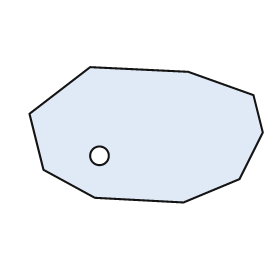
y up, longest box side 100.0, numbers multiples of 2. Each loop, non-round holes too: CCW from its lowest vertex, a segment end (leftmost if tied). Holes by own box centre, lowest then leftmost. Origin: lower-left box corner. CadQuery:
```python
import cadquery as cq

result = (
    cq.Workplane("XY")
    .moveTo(66.0, 0.0)
    .lineTo(90.0, 10.0)
    .lineTo(100.0, 30.0)
    .lineTo(96.0, 46.0)
    .lineTo(68.0, 56.0)
    .lineTo(26.0, 58.0)
    .lineTo(0.0, 38.0)
    .lineTo(6.0, 14.0)
    .lineTo(28.0, 2.0)
    .close()
    .moveTo(30.0, 20.0)
    .circle(4.0)
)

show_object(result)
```